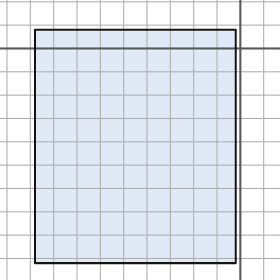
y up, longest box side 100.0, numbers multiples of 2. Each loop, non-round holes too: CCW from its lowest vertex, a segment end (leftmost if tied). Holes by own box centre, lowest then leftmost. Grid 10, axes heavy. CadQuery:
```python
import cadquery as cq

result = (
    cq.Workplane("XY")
    .moveTo(-88.0, -92.0)
    .lineTo(-2.0, -92.0)
    .lineTo(-2.0, 8.0)
    .lineTo(-88.0, 8.0)
    .close()
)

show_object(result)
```